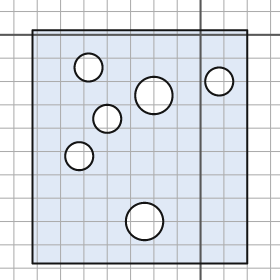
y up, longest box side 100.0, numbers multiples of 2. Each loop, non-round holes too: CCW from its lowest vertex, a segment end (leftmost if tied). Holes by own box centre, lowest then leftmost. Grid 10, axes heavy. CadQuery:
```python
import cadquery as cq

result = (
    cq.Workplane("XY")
    .moveTo(-72.0, -98.0)
    .lineTo(20.0, -98.0)
    .lineTo(20.0, 2.0)
    .lineTo(-72.0, 2.0)
    .close()
    .moveTo(-24.0, -80.0)
    .circle(8.0)
    .moveTo(-52.0, -52.0)
    .circle(6.0)
    .moveTo(-40.0, -36.0)
    .circle(6.0)
    .moveTo(-20.0, -26.0)
    .circle(8.0)
    .moveTo(8.0, -20.0)
    .circle(6.0)
    .moveTo(-48.0, -14.0)
    .circle(6.0)
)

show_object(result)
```